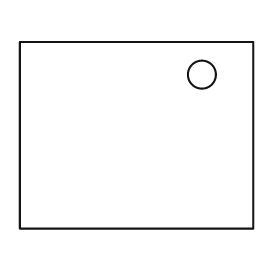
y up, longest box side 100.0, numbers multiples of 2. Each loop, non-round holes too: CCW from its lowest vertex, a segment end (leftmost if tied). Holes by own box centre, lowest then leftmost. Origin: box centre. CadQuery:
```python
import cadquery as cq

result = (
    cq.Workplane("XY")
    .moveTo(-50.0, -40.0)
    .lineTo(50.0, -40.0)
    .lineTo(50.0, 40.0)
    .lineTo(-50.0, 40.0)
    .close()
    .moveTo(28.0, 26.0)
    .circle(6.0)
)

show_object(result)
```